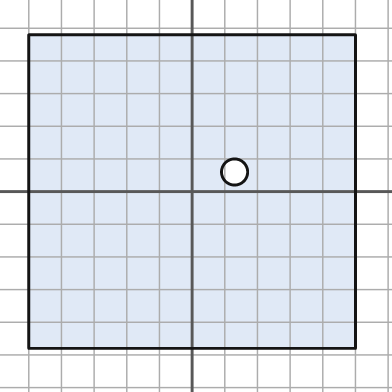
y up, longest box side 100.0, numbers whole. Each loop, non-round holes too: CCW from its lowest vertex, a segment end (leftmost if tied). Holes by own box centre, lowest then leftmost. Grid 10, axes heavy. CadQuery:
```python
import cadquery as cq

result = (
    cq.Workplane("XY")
    .moveTo(-50.0, -48.0)
    .lineTo(50.0, -48.0)
    .lineTo(50.0, 48.0)
    .lineTo(-50.0, 48.0)
    .close()
    .moveTo(13.0, 6.0)
    .circle(4.0)
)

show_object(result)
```